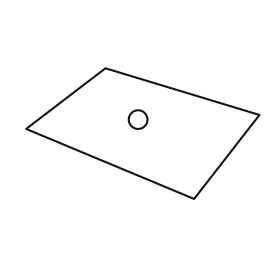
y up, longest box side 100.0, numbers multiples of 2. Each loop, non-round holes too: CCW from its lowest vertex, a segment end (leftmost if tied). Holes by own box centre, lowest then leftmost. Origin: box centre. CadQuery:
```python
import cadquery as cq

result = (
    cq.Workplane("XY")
    .moveTo(22.0, -28.0)
    .lineTo(50.0, 8.0)
    .lineTo(-16.0, 28.0)
    .lineTo(-50.0, 2.0)
    .close()
    .moveTo(-2.0, 6.0)
    .circle(4.0)
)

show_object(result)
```